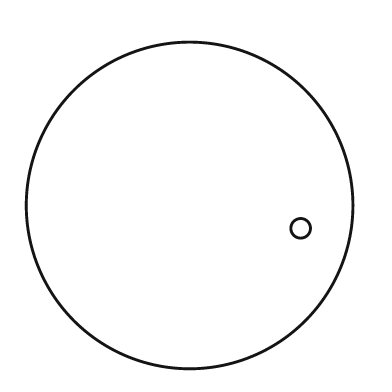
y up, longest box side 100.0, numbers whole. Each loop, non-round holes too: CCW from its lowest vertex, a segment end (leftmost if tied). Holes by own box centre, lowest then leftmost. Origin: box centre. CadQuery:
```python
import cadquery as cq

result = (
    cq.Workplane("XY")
    .moveTo(0.0, 0.0)
    .circle(50.0)
    .moveTo(34.0, -7.0)
    .circle(3.0)
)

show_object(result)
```